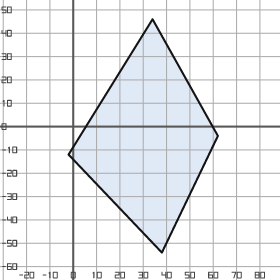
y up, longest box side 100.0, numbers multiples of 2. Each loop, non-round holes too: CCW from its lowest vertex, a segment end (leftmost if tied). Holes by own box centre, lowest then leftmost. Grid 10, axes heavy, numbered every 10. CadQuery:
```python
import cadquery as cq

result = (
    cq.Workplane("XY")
    .moveTo(38.0, -54.0)
    .lineTo(62.0, -4.0)
    .lineTo(34.0, 46.0)
    .lineTo(-2.0, -12.0)
    .close()
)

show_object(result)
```